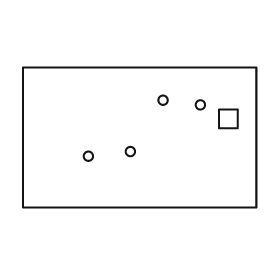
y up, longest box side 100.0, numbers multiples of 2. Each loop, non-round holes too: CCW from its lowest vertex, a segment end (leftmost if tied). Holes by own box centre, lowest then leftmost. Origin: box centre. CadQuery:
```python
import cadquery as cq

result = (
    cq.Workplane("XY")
    .moveTo(-50.0, -30.0)
    .lineTo(50.0, -30.0)
    .lineTo(50.0, 30.0)
    .lineTo(-50.0, 30.0)
    .close()
    .moveTo(-22.0, -8.0)
    .circle(2.0)
    .moveTo(-4.0, -6.0)
    .circle(2.0)
    .moveTo(34.0, 4.0)
    .lineTo(42.0, 4.0)
    .lineTo(42.0, 12.0)
    .lineTo(34.0, 12.0)
    .close()
    .moveTo(26.0, 14.0)
    .circle(2.0)
    .moveTo(10.0, 16.0)
    .circle(2.0)
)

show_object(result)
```